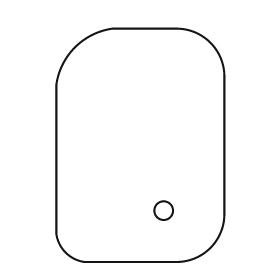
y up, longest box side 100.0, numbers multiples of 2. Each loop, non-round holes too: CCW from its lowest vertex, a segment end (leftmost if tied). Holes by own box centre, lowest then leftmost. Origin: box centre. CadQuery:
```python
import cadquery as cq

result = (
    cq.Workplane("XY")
    .moveTo(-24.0, -50.0)
    .lineTo(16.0, -50.0)
    .threePointArc((30.0, -44.0), (36.0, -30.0))
    .lineTo(36.0, 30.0)
    .threePointArc((30.0, 44.0), (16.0, 50.0))
    .lineTo(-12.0, 50.0)
    .threePointArc((-28.0, 42.0), (-36.0, 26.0))
    .lineTo(-36.0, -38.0)
    .threePointArc((-32.0, -46.0), (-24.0, -50.0))
    .close()
    .moveTo(10.0, -28.0)
    .circle(4.0)
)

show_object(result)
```